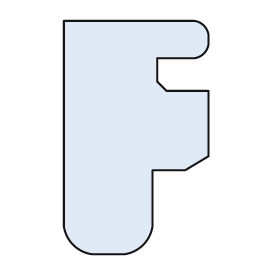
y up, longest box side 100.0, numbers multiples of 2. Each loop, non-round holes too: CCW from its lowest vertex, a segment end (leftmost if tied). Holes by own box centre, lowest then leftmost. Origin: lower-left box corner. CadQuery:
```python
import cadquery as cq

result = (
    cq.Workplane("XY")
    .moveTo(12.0, 0.0)
    .lineTo(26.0, 0.0)
    .threePointArc((34.0, 4.0), (38.0, 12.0))
    .lineTo(38.0, 36.0)
    .lineTo(52.0, 36.0)
    .lineTo(62.0, 42.0)
    .lineTo(62.0, 70.0)
    .lineTo(44.0, 70.0)
    .lineTo(40.0, 74.0)
    .lineTo(40.0, 84.0)
    .lineTo(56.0, 84.0)
    .threePointArc((60.0, 86.0), (62.0, 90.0))
    .lineTo(62.0, 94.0)
    .threePointArc((60.0, 98.0), (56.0, 100.0))
    .lineTo(0.0, 100.0)
    .lineTo(0.0, 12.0)
    .threePointArc((4.0, 4.0), (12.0, 0.0))
    .close()
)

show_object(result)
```